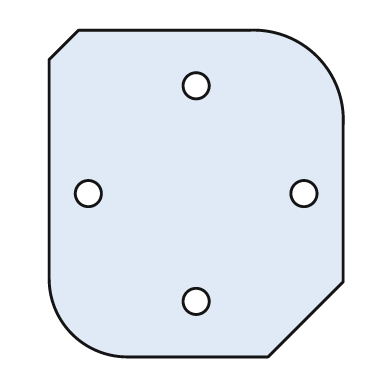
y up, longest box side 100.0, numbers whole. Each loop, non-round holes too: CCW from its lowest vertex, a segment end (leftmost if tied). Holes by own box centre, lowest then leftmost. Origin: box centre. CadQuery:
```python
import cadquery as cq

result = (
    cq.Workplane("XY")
    .moveTo(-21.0, -50.0)
    .lineTo(22.0, -50.0)
    .lineTo(45.0, -27.0)
    .lineTo(45.0, 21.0)
    .threePointArc((37.0, 42.0), (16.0, 50.0))
    .lineTo(-36.0, 50.0)
    .lineTo(-45.0, 41.0)
    .lineTo(-45.0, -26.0)
    .threePointArc((-38.0, -43.0), (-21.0, -50.0))
    .close()
    .moveTo(0.0, -33.0)
    .circle(4.0)
    .moveTo(-33.0, 0.0)
    .circle(4.0)
    .moveTo(33.0, 0.0)
    .circle(4.0)
    .moveTo(0.0, 33.0)
    .circle(4.0)
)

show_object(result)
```